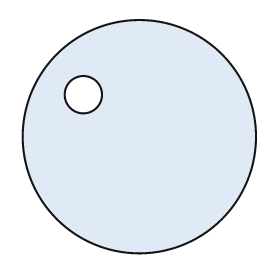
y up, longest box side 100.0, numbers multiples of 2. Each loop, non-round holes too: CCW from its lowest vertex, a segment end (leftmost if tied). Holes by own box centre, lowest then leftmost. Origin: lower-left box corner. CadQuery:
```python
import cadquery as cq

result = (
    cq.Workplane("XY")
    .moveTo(50.0, 50.0)
    .circle(50.0)
    .moveTo(26.0, 68.0)
    .circle(8.0)
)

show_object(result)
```